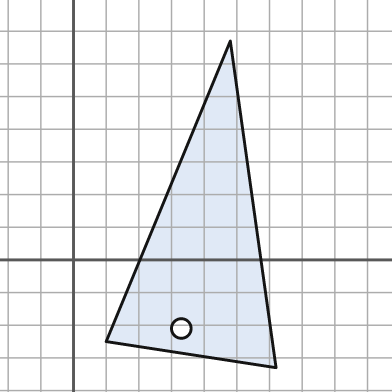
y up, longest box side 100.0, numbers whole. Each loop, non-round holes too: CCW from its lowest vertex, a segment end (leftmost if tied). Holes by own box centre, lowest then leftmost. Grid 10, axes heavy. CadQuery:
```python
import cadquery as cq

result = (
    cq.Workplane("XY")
    .moveTo(62.0, -33.0)
    .lineTo(48.0, 67.0)
    .lineTo(10.0, -25.0)
    .close()
    .moveTo(33.0, -21.0)
    .circle(3.0)
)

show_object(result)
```